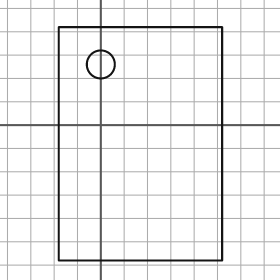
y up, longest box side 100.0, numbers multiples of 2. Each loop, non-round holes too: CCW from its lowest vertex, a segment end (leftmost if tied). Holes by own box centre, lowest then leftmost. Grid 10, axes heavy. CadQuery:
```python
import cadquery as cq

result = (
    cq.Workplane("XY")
    .moveTo(-18.0, -58.0)
    .lineTo(52.0, -58.0)
    .lineTo(52.0, 42.0)
    .lineTo(-18.0, 42.0)
    .close()
    .moveTo(0.0, 26.0)
    .circle(6.0)
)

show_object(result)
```